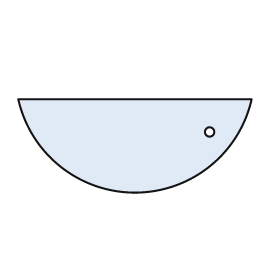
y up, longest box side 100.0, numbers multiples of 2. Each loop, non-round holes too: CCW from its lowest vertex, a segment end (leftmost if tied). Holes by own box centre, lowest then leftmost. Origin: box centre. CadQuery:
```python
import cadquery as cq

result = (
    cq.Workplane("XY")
    .moveTo(-50.0, 20.0)
    .threePointArc((0.0, -20.0), (50.0, 20.0))
    .close()
    .moveTo(32.0, 6.0)
    .circle(2.0)
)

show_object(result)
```